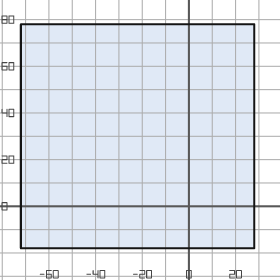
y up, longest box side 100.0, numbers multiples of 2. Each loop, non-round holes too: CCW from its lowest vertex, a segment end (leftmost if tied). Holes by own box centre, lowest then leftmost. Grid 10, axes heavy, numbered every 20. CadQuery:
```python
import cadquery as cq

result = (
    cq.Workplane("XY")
    .moveTo(-72.0, -18.0)
    .lineTo(28.0, -18.0)
    .lineTo(28.0, 78.0)
    .lineTo(-72.0, 78.0)
    .close()
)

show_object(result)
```